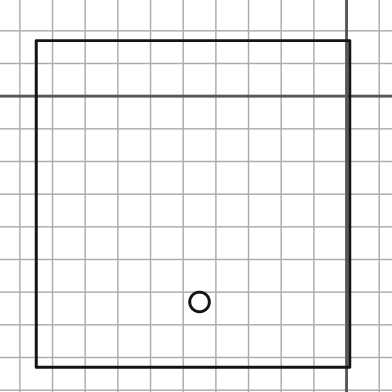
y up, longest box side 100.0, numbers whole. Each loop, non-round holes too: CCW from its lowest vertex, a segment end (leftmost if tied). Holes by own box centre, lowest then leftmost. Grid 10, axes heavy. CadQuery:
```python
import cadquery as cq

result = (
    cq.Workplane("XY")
    .moveTo(-95.0, -83.0)
    .lineTo(1.0, -83.0)
    .lineTo(1.0, 17.0)
    .lineTo(-95.0, 17.0)
    .close()
    .moveTo(-45.0, -63.0)
    .circle(3.0)
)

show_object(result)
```